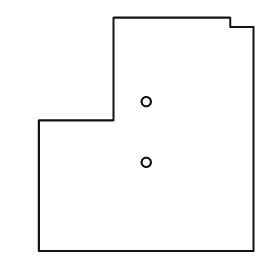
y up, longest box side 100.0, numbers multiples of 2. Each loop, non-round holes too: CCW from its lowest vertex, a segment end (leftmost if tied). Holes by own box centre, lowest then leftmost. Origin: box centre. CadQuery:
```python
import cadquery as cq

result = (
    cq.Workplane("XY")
    .moveTo(-46.0, -50.0)
    .lineTo(46.0, -50.0)
    .lineTo(46.0, 46.0)
    .lineTo(36.0, 46.0)
    .lineTo(36.0, 50.0)
    .lineTo(-14.0, 50.0)
    .lineTo(-14.0, 6.0)
    .lineTo(-46.0, 6.0)
    .close()
    .moveTo(0.0, -12.0)
    .circle(2.0)
    .moveTo(0.0, 14.0)
    .circle(2.0)
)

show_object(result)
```